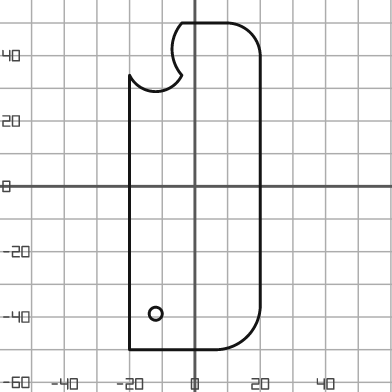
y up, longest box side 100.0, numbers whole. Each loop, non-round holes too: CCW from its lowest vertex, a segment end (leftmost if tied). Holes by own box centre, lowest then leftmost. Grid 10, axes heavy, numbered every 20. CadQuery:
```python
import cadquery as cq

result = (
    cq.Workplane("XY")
    .moveTo(-20.0, -50.0)
    .lineTo(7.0, -50.0)
    .threePointArc((16.0, -46.0), (20.0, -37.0))
    .lineTo(20.0, 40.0)
    .threePointArc((17.0, 47.0), (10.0, 50.0))
    .lineTo(-4.0, 50.0)
    .threePointArc((-7.0, 42.0), (-4.0, 34.0))
    .threePointArc((-12.0, 29.0), (-20.0, 34.0))
    .close()
    .moveTo(-12.0, -39.0)
    .circle(2.0)
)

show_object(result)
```